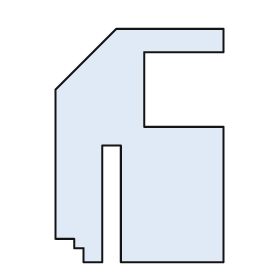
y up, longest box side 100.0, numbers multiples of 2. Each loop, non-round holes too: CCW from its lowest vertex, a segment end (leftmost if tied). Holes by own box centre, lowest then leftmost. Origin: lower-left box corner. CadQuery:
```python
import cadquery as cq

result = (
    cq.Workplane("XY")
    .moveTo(12.0, 0.0)
    .lineTo(20.0, 0.0)
    .lineTo(20.0, 50.0)
    .lineTo(28.0, 50.0)
    .lineTo(28.0, 0.0)
    .lineTo(72.0, 0.0)
    .lineTo(72.0, 58.0)
    .lineTo(38.0, 58.0)
    .lineTo(38.0, 90.0)
    .lineTo(72.0, 90.0)
    .lineTo(72.0, 100.0)
    .lineTo(26.0, 100.0)
    .lineTo(0.0, 74.0)
    .lineTo(0.0, 10.0)
    .lineTo(8.0, 10.0)
    .lineTo(8.0, 6.0)
    .lineTo(12.0, 6.0)
    .close()
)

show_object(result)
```